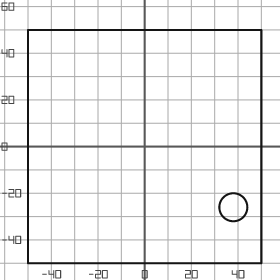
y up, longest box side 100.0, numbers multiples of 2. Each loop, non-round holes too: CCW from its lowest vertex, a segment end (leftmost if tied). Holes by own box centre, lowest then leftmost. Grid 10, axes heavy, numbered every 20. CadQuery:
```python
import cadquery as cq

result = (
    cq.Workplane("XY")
    .moveTo(-50.0, -50.0)
    .lineTo(50.0, -50.0)
    .lineTo(50.0, 50.0)
    .lineTo(-50.0, 50.0)
    .close()
    .moveTo(38.0, -26.0)
    .circle(6.0)
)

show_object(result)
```